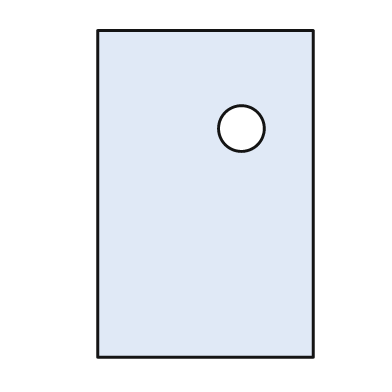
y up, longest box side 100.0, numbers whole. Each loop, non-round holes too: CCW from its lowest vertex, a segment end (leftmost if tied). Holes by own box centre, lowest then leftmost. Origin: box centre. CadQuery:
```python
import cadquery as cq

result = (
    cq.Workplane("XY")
    .moveTo(-33.0, -50.0)
    .lineTo(33.0, -50.0)
    .lineTo(33.0, 50.0)
    .lineTo(-33.0, 50.0)
    .close()
    .moveTo(11.0, 20.0)
    .circle(7.0)
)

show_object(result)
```